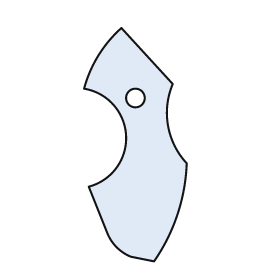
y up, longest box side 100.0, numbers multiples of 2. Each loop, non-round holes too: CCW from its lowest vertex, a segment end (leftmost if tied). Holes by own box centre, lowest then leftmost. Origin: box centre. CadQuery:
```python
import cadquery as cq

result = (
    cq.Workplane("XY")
    .moveTo(8.0, -50.0)
    .threePointArc((18.0, -30.0), (22.0, -8.0))
    .threePointArc((14.0, 8.0), (16.0, 26.0))
    .lineTo(-6.0, 50.0)
    .threePointArc((-16.0, 38.0), (-22.0, 24.0))
    .threePointArc((-4.0, 4.0), (-20.0, -18.0))
    .lineTo(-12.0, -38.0)
    .threePointArc((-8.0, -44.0), (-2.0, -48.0))
    .close()
    .moveTo(0.0, 20.0)
    .circle(4.0)
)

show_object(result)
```